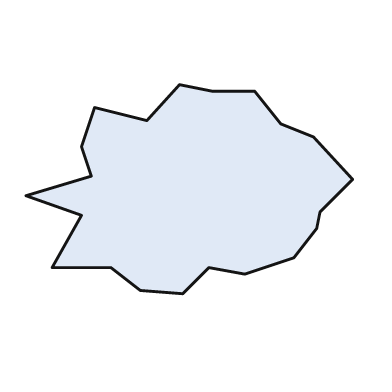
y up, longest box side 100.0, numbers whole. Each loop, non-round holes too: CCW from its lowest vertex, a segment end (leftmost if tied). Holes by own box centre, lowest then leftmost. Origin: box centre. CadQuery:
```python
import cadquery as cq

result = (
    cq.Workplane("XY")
    .moveTo(-2.0, -32.0)
    .lineTo(6.0, -24.0)
    .lineTo(17.0, -26.0)
    .lineTo(32.0, -21.0)
    .lineTo(39.0, -12.0)
    .lineTo(40.0, -7.0)
    .lineTo(50.0, 3.0)
    .lineTo(38.0, 16.0)
    .lineTo(28.0, 20.0)
    .lineTo(20.0, 30.0)
    .lineTo(7.0, 30.0)
    .lineTo(-3.0, 32.0)
    .lineTo(-13.0, 21.0)
    .lineTo(-29.0, 25.0)
    .lineTo(-33.0, 13.0)
    .lineTo(-30.0, 4.0)
    .lineTo(-50.0, -2.0)
    .lineTo(-33.0, -8.0)
    .lineTo(-42.0, -24.0)
    .lineTo(-24.0, -24.0)
    .lineTo(-15.0, -31.0)
    .close()
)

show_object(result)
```